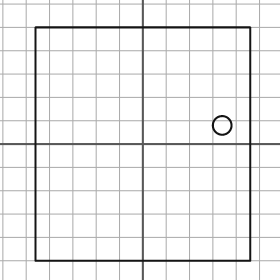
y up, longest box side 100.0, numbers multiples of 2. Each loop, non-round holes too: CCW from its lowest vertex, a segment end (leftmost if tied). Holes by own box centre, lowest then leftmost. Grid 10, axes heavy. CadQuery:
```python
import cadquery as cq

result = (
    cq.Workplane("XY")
    .moveTo(-46.0, -50.0)
    .lineTo(46.0, -50.0)
    .lineTo(46.0, 50.0)
    .lineTo(-46.0, 50.0)
    .close()
    .moveTo(34.0, 8.0)
    .circle(4.0)
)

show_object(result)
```